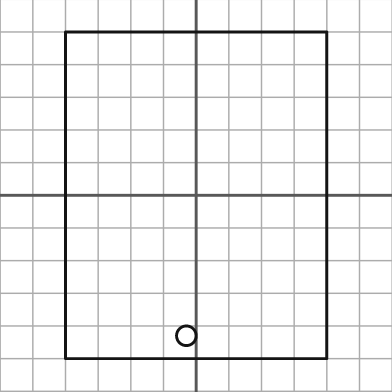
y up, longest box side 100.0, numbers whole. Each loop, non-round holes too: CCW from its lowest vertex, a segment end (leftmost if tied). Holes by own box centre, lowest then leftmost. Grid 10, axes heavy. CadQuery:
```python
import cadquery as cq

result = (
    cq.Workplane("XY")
    .moveTo(-40.0, -50.0)
    .lineTo(40.0, -50.0)
    .lineTo(40.0, 50.0)
    .lineTo(-40.0, 50.0)
    .close()
    .moveTo(-3.0, -43.0)
    .circle(3.0)
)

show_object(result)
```